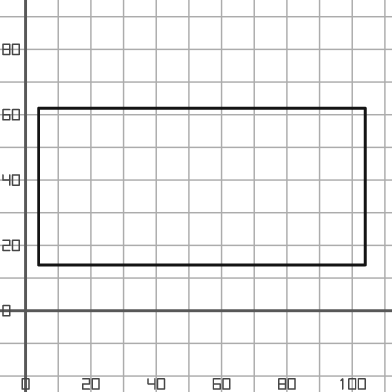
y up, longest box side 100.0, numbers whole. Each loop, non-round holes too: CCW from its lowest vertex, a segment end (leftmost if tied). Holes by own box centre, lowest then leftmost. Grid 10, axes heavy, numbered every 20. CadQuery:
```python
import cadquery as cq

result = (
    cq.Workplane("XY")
    .moveTo(4.0, 14.0)
    .lineTo(104.0, 14.0)
    .lineTo(104.0, 62.0)
    .lineTo(4.0, 62.0)
    .close()
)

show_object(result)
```